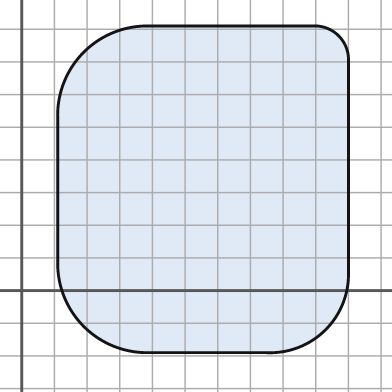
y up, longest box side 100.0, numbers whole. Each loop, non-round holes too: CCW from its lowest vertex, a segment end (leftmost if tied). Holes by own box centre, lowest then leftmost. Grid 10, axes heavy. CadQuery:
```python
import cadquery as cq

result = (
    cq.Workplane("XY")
    .moveTo(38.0, -19.0)
    .lineTo(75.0, -19.0)
    .threePointArc((93.0, -12.0), (100.0, 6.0))
    .lineTo(100.0, 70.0)
    .threePointArc((97.0, 78.0), (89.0, 81.0))
    .lineTo(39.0, 81.0)
    .threePointArc((19.0, 73.0), (11.0, 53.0))
    .lineTo(11.0, 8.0)
    .threePointArc((19.0, -11.0), (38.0, -19.0))
    .close()
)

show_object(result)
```